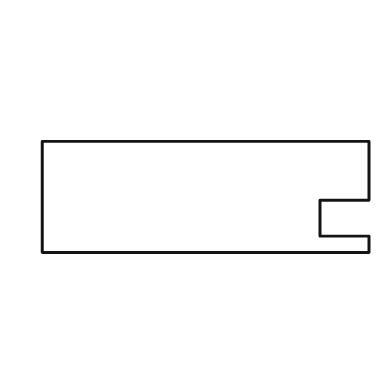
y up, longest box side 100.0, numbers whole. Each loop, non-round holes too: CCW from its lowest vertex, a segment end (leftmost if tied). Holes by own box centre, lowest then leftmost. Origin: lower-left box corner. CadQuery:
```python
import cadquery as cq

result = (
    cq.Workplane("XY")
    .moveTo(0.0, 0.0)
    .lineTo(100.0, 0.0)
    .lineTo(100.0, 5.0)
    .lineTo(85.0, 5.0)
    .lineTo(85.0, 16.0)
    .lineTo(100.0, 16.0)
    .lineTo(100.0, 34.0)
    .lineTo(0.0, 34.0)
    .close()
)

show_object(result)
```